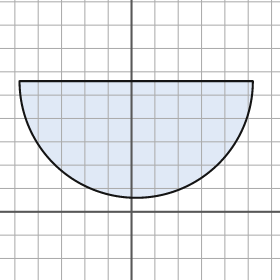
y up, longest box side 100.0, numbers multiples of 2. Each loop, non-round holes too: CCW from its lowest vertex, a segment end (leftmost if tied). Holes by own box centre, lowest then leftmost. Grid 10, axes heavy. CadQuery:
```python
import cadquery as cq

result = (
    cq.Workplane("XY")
    .moveTo(-48.0, 56.0)
    .threePointArc((2.0, 6.0), (52.0, 56.0))
    .close()
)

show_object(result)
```